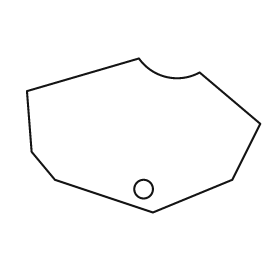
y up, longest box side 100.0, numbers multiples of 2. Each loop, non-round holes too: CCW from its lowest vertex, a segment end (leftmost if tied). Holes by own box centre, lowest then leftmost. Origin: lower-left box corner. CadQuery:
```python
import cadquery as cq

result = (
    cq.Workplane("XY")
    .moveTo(54.0, 0.0)
    .lineTo(88.0, 14.0)
    .lineTo(100.0, 38.0)
    .lineTo(74.0, 60.0)
    .threePointArc((60.0, 58.0), (48.0, 66.0))
    .lineTo(0.0, 52.0)
    .lineTo(2.0, 26.0)
    .lineTo(12.0, 14.0)
    .close()
    .moveTo(50.0, 10.0)
    .circle(4.0)
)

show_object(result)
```